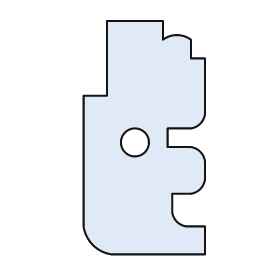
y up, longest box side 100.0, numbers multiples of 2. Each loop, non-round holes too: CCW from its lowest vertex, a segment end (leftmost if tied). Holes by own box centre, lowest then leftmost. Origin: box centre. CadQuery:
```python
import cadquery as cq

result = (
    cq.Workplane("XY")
    .moveTo(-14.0, -50.0)
    .lineTo(26.0, -50.0)
    .lineTo(26.0, -38.0)
    .lineTo(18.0, -38.0)
    .threePointArc((14.0, -36.0), (12.0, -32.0))
    .lineTo(12.0, -24.0)
    .lineTo(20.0, -24.0)
    .threePointArc((24.0, -22.0), (26.0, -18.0))
    .lineTo(26.0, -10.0)
    .threePointArc((24.0, -6.0), (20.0, -4.0))
    .lineTo(10.0, -4.0)
    .lineTo(10.0, 4.0)
    .lineTo(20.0, 4.0)
    .threePointArc((24.0, 6.0), (26.0, 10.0))
    .lineTo(26.0, 34.0)
    .lineTo(20.0, 34.0)
    .lineTo(20.0, 42.0)
    .threePointArc((14.0, 44.0), (8.0, 42.0))
    .lineTo(8.0, 50.0)
    .lineTo(-16.0, 50.0)
    .lineTo(-16.0, 18.0)
    .lineTo(-26.0, 18.0)
    .lineTo(-26.0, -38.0)
    .threePointArc((-22.0, -46.0), (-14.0, -50.0))
    .close()
    .moveTo(-4.0, -2.0)
    .circle(6.0)
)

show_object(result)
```